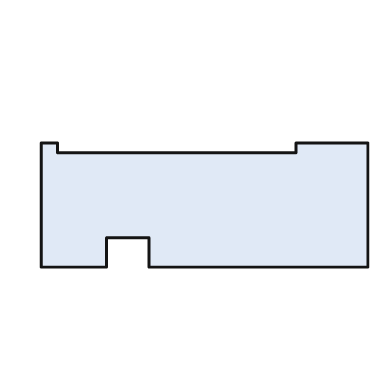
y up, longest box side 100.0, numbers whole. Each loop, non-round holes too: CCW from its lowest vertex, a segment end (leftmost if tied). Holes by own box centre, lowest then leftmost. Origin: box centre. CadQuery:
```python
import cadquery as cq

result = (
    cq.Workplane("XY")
    .moveTo(-50.0, -19.0)
    .lineTo(-30.0, -19.0)
    .lineTo(-30.0, -10.0)
    .lineTo(-17.0, -10.0)
    .lineTo(-17.0, -19.0)
    .lineTo(50.0, -19.0)
    .lineTo(50.0, 19.0)
    .lineTo(28.0, 19.0)
    .lineTo(28.0, 16.0)
    .lineTo(-45.0, 16.0)
    .lineTo(-45.0, 19.0)
    .lineTo(-50.0, 19.0)
    .close()
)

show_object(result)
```